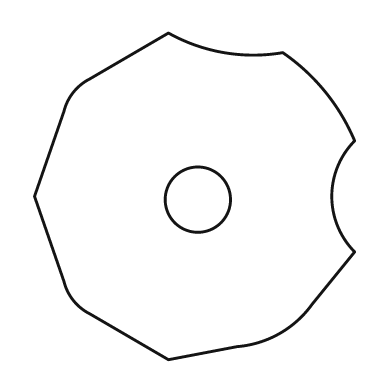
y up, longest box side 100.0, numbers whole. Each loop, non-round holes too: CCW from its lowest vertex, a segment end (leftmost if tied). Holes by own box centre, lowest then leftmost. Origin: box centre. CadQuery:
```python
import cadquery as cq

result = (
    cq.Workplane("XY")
    .moveTo(-8.0, -50.0)
    .lineTo(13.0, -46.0)
    .threePointArc((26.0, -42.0), (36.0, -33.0))
    .lineTo(49.0, -17.0)
    .threePointArc((42.0, 0.0), (49.0, 17.0))
    .threePointArc((40.0, 32.0), (27.0, 44.0))
    .threePointArc((9.0, 44.0), (-8.0, 50.0))
    .lineTo(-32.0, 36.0)
    .threePointArc((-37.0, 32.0), (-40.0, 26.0))
    .lineTo(-49.0, 0.0)
    .lineTo(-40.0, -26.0)
    .threePointArc((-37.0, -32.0), (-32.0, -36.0))
    .close()
    .moveTo(1.0, -1.0)
    .circle(10.0)
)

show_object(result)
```